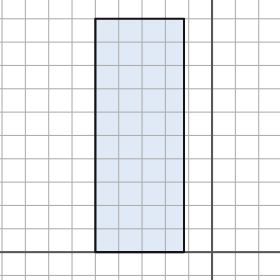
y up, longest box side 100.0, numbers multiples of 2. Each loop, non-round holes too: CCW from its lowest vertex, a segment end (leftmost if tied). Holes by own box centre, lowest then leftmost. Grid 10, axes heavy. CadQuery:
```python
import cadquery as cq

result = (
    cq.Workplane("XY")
    .moveTo(-50.0, 0.0)
    .lineTo(-12.0, 0.0)
    .lineTo(-12.0, 100.0)
    .lineTo(-50.0, 100.0)
    .close()
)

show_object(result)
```